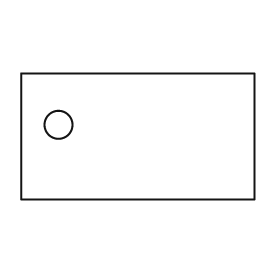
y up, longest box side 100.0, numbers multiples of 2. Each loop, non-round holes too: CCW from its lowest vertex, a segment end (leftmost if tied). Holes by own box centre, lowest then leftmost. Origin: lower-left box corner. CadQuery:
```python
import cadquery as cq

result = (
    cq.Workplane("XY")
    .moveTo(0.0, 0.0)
    .lineTo(100.0, 0.0)
    .lineTo(100.0, 54.0)
    .lineTo(0.0, 54.0)
    .close()
    .moveTo(16.0, 32.0)
    .circle(6.0)
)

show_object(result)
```